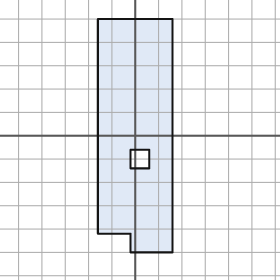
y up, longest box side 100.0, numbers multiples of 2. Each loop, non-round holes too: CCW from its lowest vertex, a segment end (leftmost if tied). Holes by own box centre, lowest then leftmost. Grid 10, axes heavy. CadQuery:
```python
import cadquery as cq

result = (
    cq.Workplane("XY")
    .moveTo(-2.0, -50.0)
    .lineTo(16.0, -50.0)
    .lineTo(16.0, 50.0)
    .lineTo(-16.0, 50.0)
    .lineTo(-16.0, -42.0)
    .lineTo(-2.0, -42.0)
    .close()
    .moveTo(-2.0, -14.0)
    .lineTo(6.0, -14.0)
    .lineTo(6.0, -6.0)
    .lineTo(-2.0, -6.0)
    .close()
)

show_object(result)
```